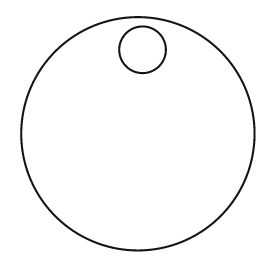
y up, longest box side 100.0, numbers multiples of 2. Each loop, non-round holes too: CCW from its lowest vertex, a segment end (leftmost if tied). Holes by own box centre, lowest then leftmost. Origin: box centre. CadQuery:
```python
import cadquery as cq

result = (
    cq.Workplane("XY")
    .moveTo(0.0, 0.0)
    .circle(50.0)
    .moveTo(2.0, 36.0)
    .circle(10.0)
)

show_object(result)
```